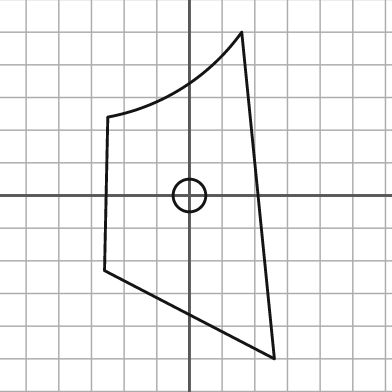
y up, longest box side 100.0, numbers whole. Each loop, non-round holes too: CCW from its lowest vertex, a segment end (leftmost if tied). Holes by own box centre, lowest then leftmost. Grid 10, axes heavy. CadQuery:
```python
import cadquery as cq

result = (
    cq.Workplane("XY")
    .moveTo(26.0, -50.0)
    .lineTo(16.0, 50.0)
    .threePointArc((-2.0, 33.0), (-25.0, 24.0))
    .lineTo(-26.0, -23.0)
    .close()
    .moveTo(0.0, 0.0)
    .circle(5.0)
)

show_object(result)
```